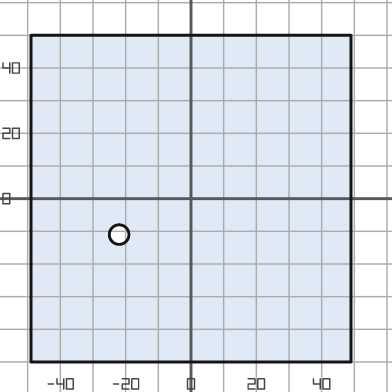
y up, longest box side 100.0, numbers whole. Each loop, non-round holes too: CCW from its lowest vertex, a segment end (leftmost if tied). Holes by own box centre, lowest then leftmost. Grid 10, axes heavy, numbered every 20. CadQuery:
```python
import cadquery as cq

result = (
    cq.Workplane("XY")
    .moveTo(-49.0, -50.0)
    .lineTo(49.0, -50.0)
    .lineTo(49.0, 50.0)
    .lineTo(-49.0, 50.0)
    .close()
    .moveTo(-22.0, -11.0)
    .circle(3.0)
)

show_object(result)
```